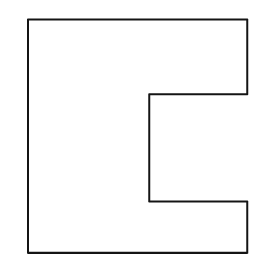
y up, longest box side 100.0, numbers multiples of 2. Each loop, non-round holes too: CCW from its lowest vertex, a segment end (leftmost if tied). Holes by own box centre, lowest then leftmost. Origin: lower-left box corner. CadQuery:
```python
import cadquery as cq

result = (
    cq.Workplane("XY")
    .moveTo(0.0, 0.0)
    .lineTo(94.0, 0.0)
    .lineTo(94.0, 22.0)
    .lineTo(52.0, 22.0)
    .lineTo(52.0, 68.0)
    .lineTo(94.0, 68.0)
    .lineTo(94.0, 100.0)
    .lineTo(0.0, 100.0)
    .close()
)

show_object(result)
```